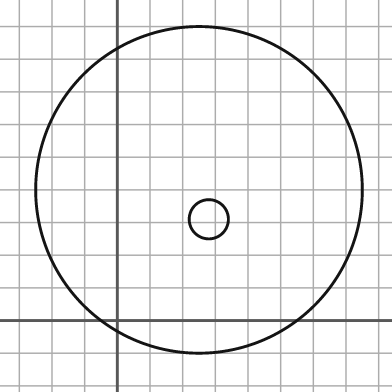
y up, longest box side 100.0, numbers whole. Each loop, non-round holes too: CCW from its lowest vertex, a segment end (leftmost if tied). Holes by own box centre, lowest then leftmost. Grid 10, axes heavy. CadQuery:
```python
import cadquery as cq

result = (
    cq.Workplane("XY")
    .moveTo(25.0, 40.0)
    .circle(50.0)
    .moveTo(28.0, 31.0)
    .circle(6.0)
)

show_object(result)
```